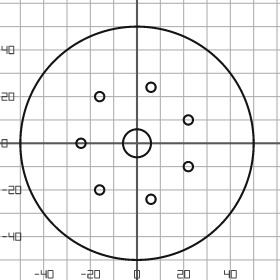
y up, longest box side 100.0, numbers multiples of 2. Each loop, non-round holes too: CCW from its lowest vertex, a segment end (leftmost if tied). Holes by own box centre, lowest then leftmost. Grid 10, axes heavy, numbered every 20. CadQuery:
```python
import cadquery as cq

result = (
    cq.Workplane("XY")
    .moveTo(0.0, 0.0)
    .circle(50.0)
    .moveTo(6.0, -24.0)
    .circle(2.0)
    .moveTo(-16.0, -20.0)
    .circle(2.0)
    .moveTo(22.0, -10.0)
    .circle(2.0)
    .moveTo(-24.0, 0.0)
    .circle(2.0)
    .moveTo(0.0, 0.0)
    .circle(6.0)
    .moveTo(22.0, 10.0)
    .circle(2.0)
    .moveTo(-16.0, 20.0)
    .circle(2.0)
    .moveTo(6.0, 24.0)
    .circle(2.0)
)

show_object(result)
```